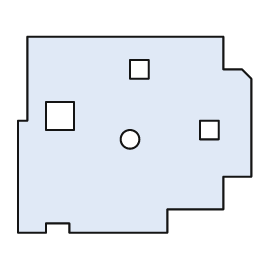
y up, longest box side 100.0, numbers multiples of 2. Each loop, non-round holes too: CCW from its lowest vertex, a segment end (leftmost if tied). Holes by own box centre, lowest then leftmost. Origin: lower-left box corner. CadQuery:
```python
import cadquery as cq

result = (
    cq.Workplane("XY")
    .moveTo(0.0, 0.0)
    .lineTo(12.0, 0.0)
    .lineTo(12.0, 4.0)
    .lineTo(22.0, 4.0)
    .lineTo(22.0, 0.0)
    .lineTo(64.0, 0.0)
    .lineTo(64.0, 10.0)
    .lineTo(88.0, 10.0)
    .lineTo(88.0, 24.0)
    .lineTo(100.0, 24.0)
    .lineTo(100.0, 66.0)
    .lineTo(96.0, 70.0)
    .lineTo(88.0, 70.0)
    .lineTo(88.0, 84.0)
    .lineTo(4.0, 84.0)
    .lineTo(4.0, 48.0)
    .lineTo(0.0, 48.0)
    .close()
    .moveTo(48.0, 40.0)
    .circle(4.0)
    .moveTo(78.0, 40.0)
    .lineTo(86.0, 40.0)
    .lineTo(86.0, 48.0)
    .lineTo(78.0, 48.0)
    .close()
    .moveTo(12.0, 44.0)
    .lineTo(24.0, 44.0)
    .lineTo(24.0, 56.0)
    .lineTo(12.0, 56.0)
    .close()
    .moveTo(48.0, 66.0)
    .lineTo(56.0, 66.0)
    .lineTo(56.0, 74.0)
    .lineTo(48.0, 74.0)
    .close()
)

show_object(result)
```